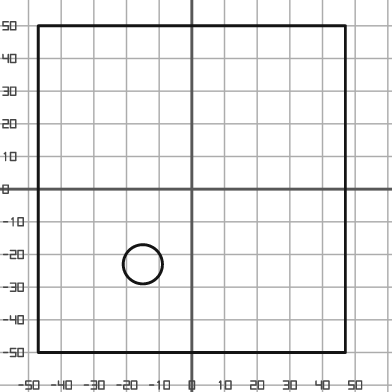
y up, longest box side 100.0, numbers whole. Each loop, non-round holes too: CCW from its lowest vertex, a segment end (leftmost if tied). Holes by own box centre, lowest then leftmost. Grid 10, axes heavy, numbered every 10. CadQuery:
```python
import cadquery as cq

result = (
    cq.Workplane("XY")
    .moveTo(-47.0, -50.0)
    .lineTo(47.0, -50.0)
    .lineTo(47.0, 50.0)
    .lineTo(-47.0, 50.0)
    .close()
    .moveTo(-15.0, -23.0)
    .circle(6.0)
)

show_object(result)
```